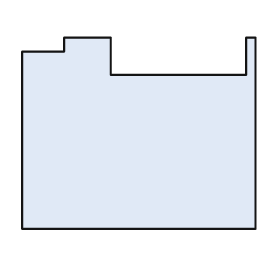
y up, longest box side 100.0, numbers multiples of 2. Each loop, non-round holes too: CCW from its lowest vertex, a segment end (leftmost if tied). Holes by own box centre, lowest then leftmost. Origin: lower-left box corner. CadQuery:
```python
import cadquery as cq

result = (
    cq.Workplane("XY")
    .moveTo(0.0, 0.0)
    .lineTo(100.0, 0.0)
    .lineTo(100.0, 82.0)
    .lineTo(96.0, 82.0)
    .lineTo(96.0, 66.0)
    .lineTo(38.0, 66.0)
    .lineTo(38.0, 82.0)
    .lineTo(18.0, 82.0)
    .lineTo(18.0, 76.0)
    .lineTo(0.0, 76.0)
    .close()
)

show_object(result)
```